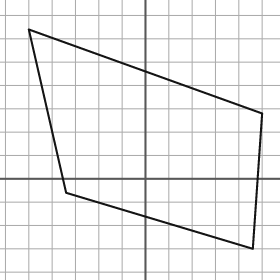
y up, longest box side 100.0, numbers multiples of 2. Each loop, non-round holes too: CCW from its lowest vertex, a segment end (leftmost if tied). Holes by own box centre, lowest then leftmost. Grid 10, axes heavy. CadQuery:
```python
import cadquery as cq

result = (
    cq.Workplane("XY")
    .moveTo(46.0, -30.0)
    .lineTo(50.0, 28.0)
    .lineTo(-50.0, 64.0)
    .lineTo(-34.0, -6.0)
    .close()
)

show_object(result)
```